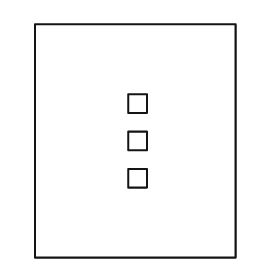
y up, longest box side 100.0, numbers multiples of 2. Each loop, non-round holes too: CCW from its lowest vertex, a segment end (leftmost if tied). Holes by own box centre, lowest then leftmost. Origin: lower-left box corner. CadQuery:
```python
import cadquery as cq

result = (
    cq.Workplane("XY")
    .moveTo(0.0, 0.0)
    .lineTo(86.0, 0.0)
    .lineTo(86.0, 100.0)
    .lineTo(0.0, 100.0)
    .close()
    .moveTo(40.0, 30.0)
    .lineTo(48.0, 30.0)
    .lineTo(48.0, 38.0)
    .lineTo(40.0, 38.0)
    .close()
    .moveTo(40.0, 46.0)
    .lineTo(48.0, 46.0)
    .lineTo(48.0, 54.0)
    .lineTo(40.0, 54.0)
    .close()
    .moveTo(40.0, 62.0)
    .lineTo(48.0, 62.0)
    .lineTo(48.0, 70.0)
    .lineTo(40.0, 70.0)
    .close()
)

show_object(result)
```